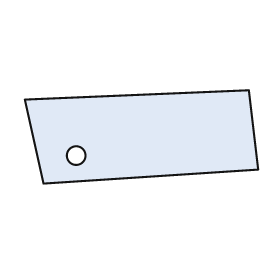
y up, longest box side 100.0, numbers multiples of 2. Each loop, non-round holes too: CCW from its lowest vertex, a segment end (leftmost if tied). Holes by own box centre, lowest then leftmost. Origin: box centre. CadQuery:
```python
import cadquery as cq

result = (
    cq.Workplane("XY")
    .moveTo(-42.0, -20.0)
    .lineTo(50.0, -14.0)
    .lineTo(46.0, 20.0)
    .lineTo(-50.0, 16.0)
    .close()
    .moveTo(-28.0, -8.0)
    .circle(4.0)
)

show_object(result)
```